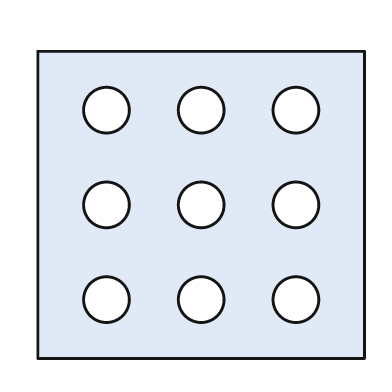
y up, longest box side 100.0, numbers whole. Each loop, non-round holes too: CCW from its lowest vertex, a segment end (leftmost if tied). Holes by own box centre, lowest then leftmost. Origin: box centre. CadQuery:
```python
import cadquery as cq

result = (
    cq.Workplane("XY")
    .moveTo(-50.0, -47.0)
    .lineTo(50.0, -47.0)
    .lineTo(50.0, 47.0)
    .lineTo(-50.0, 47.0)
    .close()
    .moveTo(-29.0, -29.0)
    .circle(7.0)
    .moveTo(0.0, -29.0)
    .circle(7.0)
    .moveTo(29.0, -29.0)
    .circle(7.0)
    .moveTo(-29.0, 0.0)
    .circle(7.0)
    .moveTo(0.0, 0.0)
    .circle(7.0)
    .moveTo(29.0, 0.0)
    .circle(7.0)
    .moveTo(-29.0, 29.0)
    .circle(7.0)
    .moveTo(0.0, 29.0)
    .circle(7.0)
    .moveTo(29.0, 29.0)
    .circle(7.0)
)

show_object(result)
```